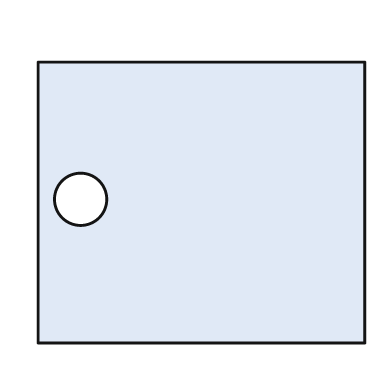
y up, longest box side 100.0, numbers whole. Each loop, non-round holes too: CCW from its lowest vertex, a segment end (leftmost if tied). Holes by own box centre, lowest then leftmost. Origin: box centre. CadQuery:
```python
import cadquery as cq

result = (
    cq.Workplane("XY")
    .moveTo(-50.0, -43.0)
    .lineTo(50.0, -43.0)
    .lineTo(50.0, 43.0)
    .lineTo(-50.0, 43.0)
    .close()
    .moveTo(-37.0, 1.0)
    .circle(8.0)
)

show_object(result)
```